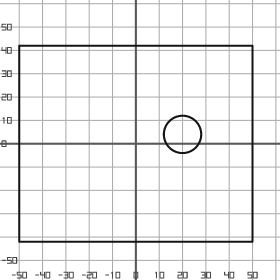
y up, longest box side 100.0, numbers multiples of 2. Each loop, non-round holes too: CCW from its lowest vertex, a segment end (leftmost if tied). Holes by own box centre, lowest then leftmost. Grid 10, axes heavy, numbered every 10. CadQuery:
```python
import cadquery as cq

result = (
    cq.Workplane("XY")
    .moveTo(-50.0, -42.0)
    .lineTo(50.0, -42.0)
    .lineTo(50.0, 42.0)
    .lineTo(-50.0, 42.0)
    .close()
    .moveTo(20.0, 4.0)
    .circle(8.0)
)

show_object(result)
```